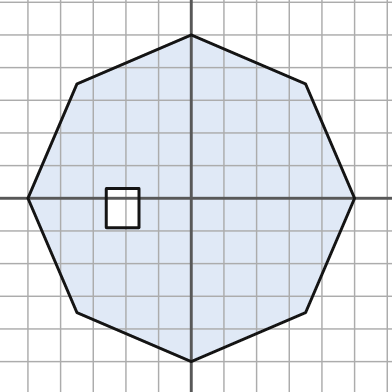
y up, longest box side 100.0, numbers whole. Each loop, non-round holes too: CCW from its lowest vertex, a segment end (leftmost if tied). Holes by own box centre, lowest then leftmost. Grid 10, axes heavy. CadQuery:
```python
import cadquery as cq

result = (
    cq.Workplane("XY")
    .moveTo(0.0, -50.0)
    .lineTo(35.0, -35.0)
    .lineTo(50.0, 0.0)
    .lineTo(35.0, 35.0)
    .lineTo(0.0, 50.0)
    .lineTo(-35.0, 35.0)
    .lineTo(-50.0, 0.0)
    .lineTo(-35.0, -35.0)
    .close()
    .moveTo(-26.0, -9.0)
    .lineTo(-16.0, -9.0)
    .lineTo(-16.0, 3.0)
    .lineTo(-26.0, 3.0)
    .close()
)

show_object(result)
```